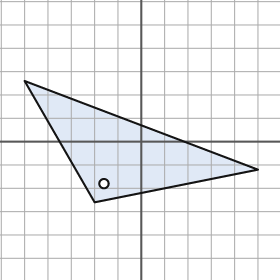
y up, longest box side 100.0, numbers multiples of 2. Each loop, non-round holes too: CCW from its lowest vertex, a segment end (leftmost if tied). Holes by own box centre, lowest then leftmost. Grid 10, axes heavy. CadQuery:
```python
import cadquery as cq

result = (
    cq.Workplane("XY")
    .moveTo(-20.0, -26.0)
    .lineTo(50.0, -12.0)
    .lineTo(-50.0, 26.0)
    .close()
    .moveTo(-16.0, -18.0)
    .circle(2.0)
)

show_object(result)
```